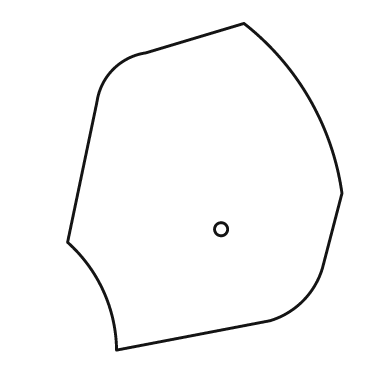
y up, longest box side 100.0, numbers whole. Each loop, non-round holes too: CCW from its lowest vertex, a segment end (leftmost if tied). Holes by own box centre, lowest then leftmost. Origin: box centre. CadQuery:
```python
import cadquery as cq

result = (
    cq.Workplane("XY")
    .moveTo(-27.0, -50.0)
    .lineTo(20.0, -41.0)
    .threePointArc((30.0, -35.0), (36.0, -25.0))
    .lineTo(42.0, -2.0)
    .threePointArc((32.0, 27.0), (12.0, 50.0))
    .lineTo(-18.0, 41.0)
    .threePointArc((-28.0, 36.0), (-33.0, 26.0))
    .lineTo(-42.0, -17.0)
    .threePointArc((-31.0, -32.0), (-27.0, -50.0))
    .close()
    .moveTo(5.0, -13.0)
    .circle(2.0)
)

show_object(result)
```